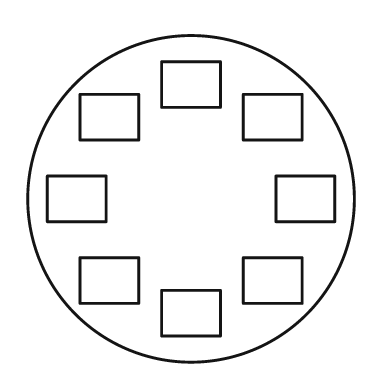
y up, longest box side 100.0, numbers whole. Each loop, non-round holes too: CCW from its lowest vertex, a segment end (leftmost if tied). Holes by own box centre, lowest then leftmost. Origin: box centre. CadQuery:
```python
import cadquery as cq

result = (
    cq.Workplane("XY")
    .moveTo(0.0, 0.0)
    .circle(50.0)
    .moveTo(-9.0, -42.0)
    .lineTo(9.0, -42.0)
    .lineTo(9.0, -28.0)
    .lineTo(-9.0, -28.0)
    .close()
    .moveTo(-34.0, -32.0)
    .lineTo(-16.0, -32.0)
    .lineTo(-16.0, -18.0)
    .lineTo(-34.0, -18.0)
    .close()
    .moveTo(16.0, -32.0)
    .lineTo(34.0, -32.0)
    .lineTo(34.0, -18.0)
    .lineTo(16.0, -18.0)
    .close()
    .moveTo(-44.0, -7.0)
    .lineTo(-26.0, -7.0)
    .lineTo(-26.0, 7.0)
    .lineTo(-44.0, 7.0)
    .close()
    .moveTo(26.0, -7.0)
    .lineTo(44.0, -7.0)
    .lineTo(44.0, 7.0)
    .lineTo(26.0, 7.0)
    .close()
    .moveTo(-34.0, 18.0)
    .lineTo(-16.0, 18.0)
    .lineTo(-16.0, 32.0)
    .lineTo(-34.0, 32.0)
    .close()
    .moveTo(16.0, 18.0)
    .lineTo(34.0, 18.0)
    .lineTo(34.0, 32.0)
    .lineTo(16.0, 32.0)
    .close()
    .moveTo(-9.0, 28.0)
    .lineTo(9.0, 28.0)
    .lineTo(9.0, 42.0)
    .lineTo(-9.0, 42.0)
    .close()
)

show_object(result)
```